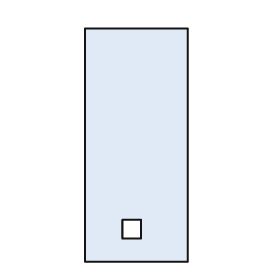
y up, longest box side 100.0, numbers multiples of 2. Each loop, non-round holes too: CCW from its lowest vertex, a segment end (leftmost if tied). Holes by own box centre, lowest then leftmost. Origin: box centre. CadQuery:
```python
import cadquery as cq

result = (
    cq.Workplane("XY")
    .moveTo(-22.0, -50.0)
    .lineTo(22.0, -50.0)
    .lineTo(22.0, 50.0)
    .lineTo(-22.0, 50.0)
    .close()
    .moveTo(-6.0, -40.0)
    .lineTo(2.0, -40.0)
    .lineTo(2.0, -32.0)
    .lineTo(-6.0, -32.0)
    .close()
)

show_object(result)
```